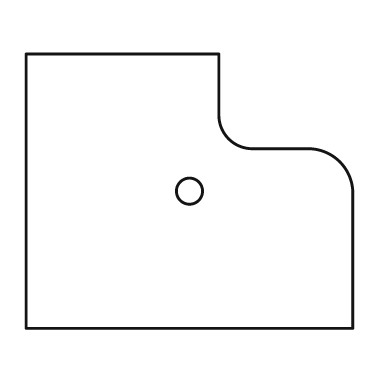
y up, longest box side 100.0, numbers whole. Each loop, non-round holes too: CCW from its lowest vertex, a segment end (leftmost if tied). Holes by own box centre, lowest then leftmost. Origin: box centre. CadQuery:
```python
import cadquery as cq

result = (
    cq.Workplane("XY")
    .moveTo(-50.0, -42.0)
    .lineTo(50.0, -42.0)
    .lineTo(50.0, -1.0)
    .threePointArc((46.0, 9.0), (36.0, 13.0))
    .lineTo(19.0, 13.0)
    .threePointArc((12.0, 16.0), (9.0, 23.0))
    .lineTo(9.0, 42.0)
    .lineTo(-50.0, 42.0)
    .close()
    .moveTo(0.0, 0.0)
    .circle(4.0)
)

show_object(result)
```